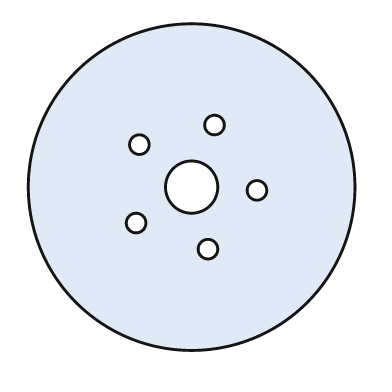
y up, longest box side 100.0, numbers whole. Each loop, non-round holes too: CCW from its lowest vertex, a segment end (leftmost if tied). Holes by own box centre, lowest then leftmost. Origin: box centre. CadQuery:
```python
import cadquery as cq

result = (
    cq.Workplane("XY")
    .moveTo(0.0, 0.0)
    .circle(50.0)
    .moveTo(5.0, -19.0)
    .circle(3.0)
    .moveTo(-17.0, -11.0)
    .circle(3.0)
    .moveTo(20.0, -1.0)
    .circle(3.0)
    .moveTo(0.0, 0.0)
    .circle(8.0)
    .moveTo(-16.0, 13.0)
    .circle(3.0)
    .moveTo(7.0, 19.0)
    .circle(3.0)
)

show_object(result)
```